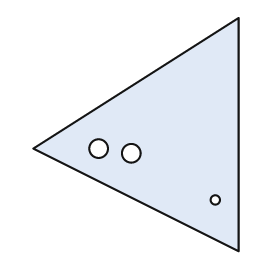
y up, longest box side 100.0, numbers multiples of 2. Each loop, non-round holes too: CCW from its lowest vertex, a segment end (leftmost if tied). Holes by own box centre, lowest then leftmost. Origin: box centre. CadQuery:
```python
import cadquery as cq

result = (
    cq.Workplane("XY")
    .moveTo(44.0, -50.0)
    .lineTo(44.0, 50.0)
    .lineTo(-44.0, -6.0)
    .close()
    .moveTo(34.0, -28.0)
    .circle(2.0)
    .moveTo(-2.0, -8.0)
    .circle(4.0)
    .moveTo(-16.0, -6.0)
    .circle(4.0)
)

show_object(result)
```